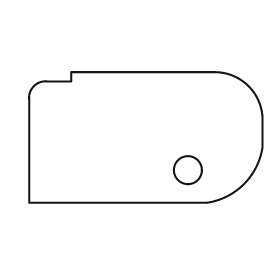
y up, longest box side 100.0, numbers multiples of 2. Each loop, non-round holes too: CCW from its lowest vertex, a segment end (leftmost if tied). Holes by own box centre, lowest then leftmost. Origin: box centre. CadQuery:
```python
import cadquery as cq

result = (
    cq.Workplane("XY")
    .moveTo(-50.0, -28.0)
    .lineTo(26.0, -28.0)
    .threePointArc((42.0, -20.0), (50.0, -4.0))
    .lineTo(50.0, 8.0)
    .threePointArc((44.0, 22.0), (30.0, 28.0))
    .lineTo(-32.0, 28.0)
    .lineTo(-32.0, 24.0)
    .lineTo(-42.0, 24.0)
    .threePointArc((-48.0, 22.0), (-50.0, 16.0))
    .close()
    .moveTo(18.0, -14.0)
    .circle(6.0)
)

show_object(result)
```